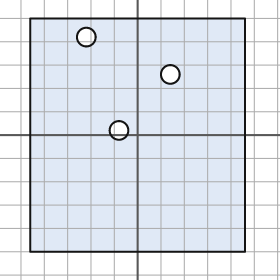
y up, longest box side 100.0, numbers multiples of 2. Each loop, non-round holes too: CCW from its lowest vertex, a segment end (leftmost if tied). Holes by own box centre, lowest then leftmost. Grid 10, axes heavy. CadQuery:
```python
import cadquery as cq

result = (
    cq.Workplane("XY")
    .moveTo(-46.0, -50.0)
    .lineTo(46.0, -50.0)
    .lineTo(46.0, 50.0)
    .lineTo(-46.0, 50.0)
    .close()
    .moveTo(-8.0, 2.0)
    .circle(4.0)
    .moveTo(14.0, 26.0)
    .circle(4.0)
    .moveTo(-22.0, 42.0)
    .circle(4.0)
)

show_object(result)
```